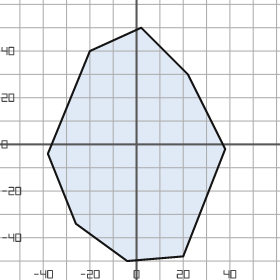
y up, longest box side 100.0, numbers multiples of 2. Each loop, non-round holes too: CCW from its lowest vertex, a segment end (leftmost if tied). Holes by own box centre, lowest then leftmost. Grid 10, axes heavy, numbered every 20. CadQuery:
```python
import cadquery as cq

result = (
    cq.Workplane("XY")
    .moveTo(-4.0, -50.0)
    .lineTo(20.0, -48.0)
    .lineTo(38.0, -2.0)
    .lineTo(22.0, 30.0)
    .lineTo(2.0, 50.0)
    .lineTo(-20.0, 40.0)
    .lineTo(-38.0, -4.0)
    .lineTo(-26.0, -34.0)
    .close()
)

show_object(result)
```